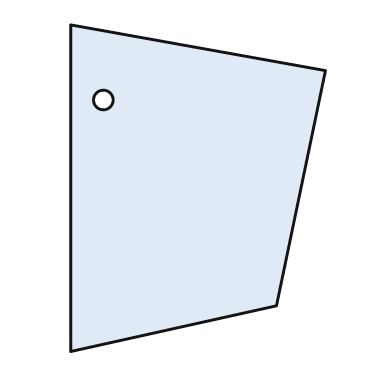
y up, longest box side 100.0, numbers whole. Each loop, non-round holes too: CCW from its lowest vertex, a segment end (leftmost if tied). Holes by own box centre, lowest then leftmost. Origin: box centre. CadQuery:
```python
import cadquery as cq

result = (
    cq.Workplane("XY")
    .moveTo(-39.0, -50.0)
    .lineTo(24.0, -36.0)
    .lineTo(39.0, 36.0)
    .lineTo(-39.0, 50.0)
    .close()
    .moveTo(-29.0, 27.0)
    .circle(3.0)
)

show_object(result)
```